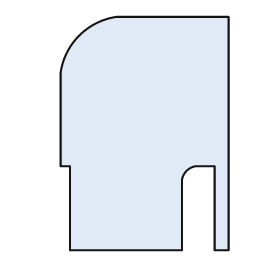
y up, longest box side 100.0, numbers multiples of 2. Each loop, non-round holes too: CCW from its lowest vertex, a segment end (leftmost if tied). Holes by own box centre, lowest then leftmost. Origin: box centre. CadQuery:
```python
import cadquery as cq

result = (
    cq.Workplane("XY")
    .moveTo(-32.0, -50.0)
    .lineTo(16.0, -50.0)
    .lineTo(16.0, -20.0)
    .threePointArc((18.0, -16.0), (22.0, -14.0))
    .lineTo(30.0, -14.0)
    .lineTo(30.0, -50.0)
    .lineTo(36.0, -50.0)
    .lineTo(36.0, 50.0)
    .lineTo(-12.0, 50.0)
    .threePointArc((-28.0, 42.0), (-36.0, 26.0))
    .lineTo(-36.0, -14.0)
    .lineTo(-32.0, -14.0)
    .close()
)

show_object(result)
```